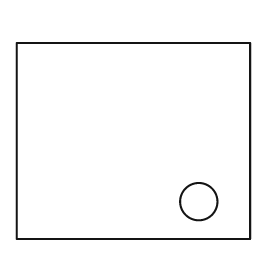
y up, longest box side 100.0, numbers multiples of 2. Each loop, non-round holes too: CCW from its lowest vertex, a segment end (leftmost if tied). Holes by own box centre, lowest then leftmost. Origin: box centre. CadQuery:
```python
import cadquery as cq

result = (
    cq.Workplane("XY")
    .moveTo(-50.0, -42.0)
    .lineTo(50.0, -42.0)
    .lineTo(50.0, 42.0)
    .lineTo(-50.0, 42.0)
    .close()
    .moveTo(28.0, -26.0)
    .circle(8.0)
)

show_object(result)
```